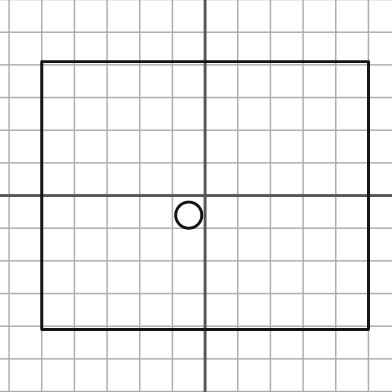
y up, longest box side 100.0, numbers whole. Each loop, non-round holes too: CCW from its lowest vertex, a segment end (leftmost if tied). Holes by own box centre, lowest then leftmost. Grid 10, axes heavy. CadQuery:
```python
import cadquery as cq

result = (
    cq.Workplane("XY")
    .moveTo(-50.0, -41.0)
    .lineTo(50.0, -41.0)
    .lineTo(50.0, 41.0)
    .lineTo(-50.0, 41.0)
    .close()
    .moveTo(-5.0, -6.0)
    .circle(4.0)
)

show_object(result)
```